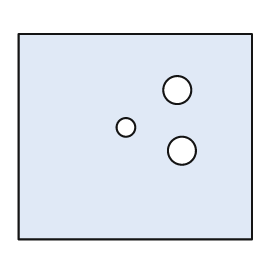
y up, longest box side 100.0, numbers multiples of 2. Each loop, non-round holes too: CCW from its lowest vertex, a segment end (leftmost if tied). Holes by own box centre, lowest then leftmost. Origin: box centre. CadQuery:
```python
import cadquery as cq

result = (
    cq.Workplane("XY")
    .moveTo(-50.0, -44.0)
    .lineTo(50.0, -44.0)
    .lineTo(50.0, 44.0)
    .lineTo(-50.0, 44.0)
    .close()
    .moveTo(20.0, -6.0)
    .circle(6.0)
    .moveTo(-4.0, 4.0)
    .circle(4.0)
    .moveTo(18.0, 20.0)
    .circle(6.0)
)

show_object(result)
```